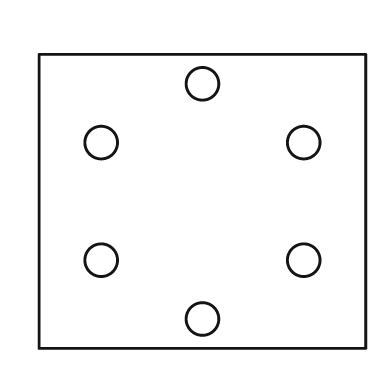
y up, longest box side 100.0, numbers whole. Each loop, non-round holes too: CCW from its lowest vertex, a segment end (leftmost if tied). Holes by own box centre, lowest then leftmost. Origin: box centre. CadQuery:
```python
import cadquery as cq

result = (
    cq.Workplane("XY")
    .moveTo(-50.0, -45.0)
    .lineTo(50.0, -45.0)
    .lineTo(50.0, 45.0)
    .lineTo(-50.0, 45.0)
    .close()
    .moveTo(0.0, -36.0)
    .circle(5.0)
    .moveTo(-31.0, -18.0)
    .circle(5.0)
    .moveTo(31.0, -18.0)
    .circle(5.0)
    .moveTo(-31.0, 18.0)
    .circle(5.0)
    .moveTo(31.0, 18.0)
    .circle(5.0)
    .moveTo(0.0, 36.0)
    .circle(5.0)
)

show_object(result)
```